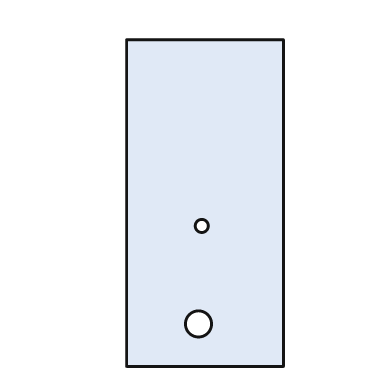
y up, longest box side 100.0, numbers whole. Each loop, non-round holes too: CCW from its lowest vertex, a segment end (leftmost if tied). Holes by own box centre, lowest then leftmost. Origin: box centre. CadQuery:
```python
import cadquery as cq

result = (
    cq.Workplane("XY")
    .moveTo(-24.0, -50.0)
    .lineTo(24.0, -50.0)
    .lineTo(24.0, 50.0)
    .lineTo(-24.0, 50.0)
    .close()
    .moveTo(-2.0, -37.0)
    .circle(4.0)
    .moveTo(-1.0, -7.0)
    .circle(2.0)
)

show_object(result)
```